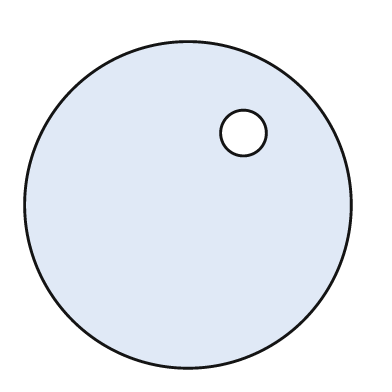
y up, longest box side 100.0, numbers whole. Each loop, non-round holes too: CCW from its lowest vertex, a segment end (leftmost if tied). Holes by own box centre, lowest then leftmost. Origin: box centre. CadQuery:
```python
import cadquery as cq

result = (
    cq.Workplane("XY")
    .moveTo(0.0, 0.0)
    .circle(50.0)
    .moveTo(17.0, 22.0)
    .circle(7.0)
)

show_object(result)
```